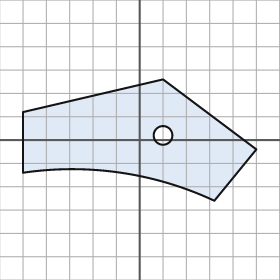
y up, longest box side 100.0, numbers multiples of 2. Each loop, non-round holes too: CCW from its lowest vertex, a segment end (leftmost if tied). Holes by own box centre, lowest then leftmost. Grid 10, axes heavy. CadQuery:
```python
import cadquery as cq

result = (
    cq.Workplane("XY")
    .moveTo(32.0, -26.0)
    .lineTo(50.0, -4.0)
    .lineTo(10.0, 26.0)
    .lineTo(-50.0, 12.0)
    .lineTo(-50.0, -14.0)
    .threePointArc((-8.0, -14.0), (32.0, -26.0))
    .close()
    .moveTo(10.0, 2.0)
    .circle(4.0)
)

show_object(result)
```